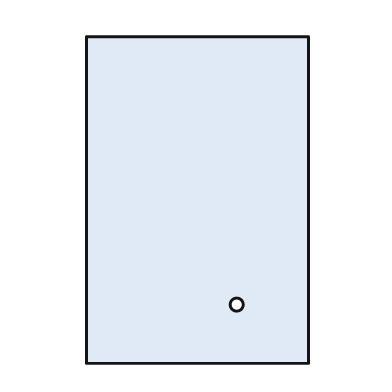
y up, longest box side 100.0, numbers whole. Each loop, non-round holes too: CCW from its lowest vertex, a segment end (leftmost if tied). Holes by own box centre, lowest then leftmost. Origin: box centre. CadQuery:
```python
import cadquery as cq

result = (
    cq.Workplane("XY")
    .moveTo(-34.0, -50.0)
    .lineTo(34.0, -50.0)
    .lineTo(34.0, 50.0)
    .lineTo(-34.0, 50.0)
    .close()
    .moveTo(12.0, -32.0)
    .circle(2.0)
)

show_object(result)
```